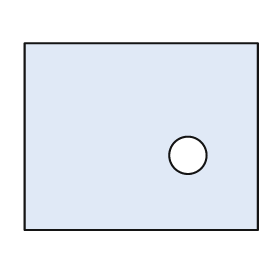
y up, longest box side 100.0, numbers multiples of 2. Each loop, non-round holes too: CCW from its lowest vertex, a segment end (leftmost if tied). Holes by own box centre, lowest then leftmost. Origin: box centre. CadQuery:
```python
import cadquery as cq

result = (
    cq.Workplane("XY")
    .moveTo(-50.0, -40.0)
    .lineTo(50.0, -40.0)
    .lineTo(50.0, 40.0)
    .lineTo(-50.0, 40.0)
    .close()
    .moveTo(20.0, -8.0)
    .circle(8.0)
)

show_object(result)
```